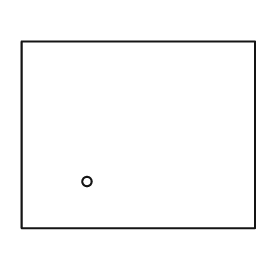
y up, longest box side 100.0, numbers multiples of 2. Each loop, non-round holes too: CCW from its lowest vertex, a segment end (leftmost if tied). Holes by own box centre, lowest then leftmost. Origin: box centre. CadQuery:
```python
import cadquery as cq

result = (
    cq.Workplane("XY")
    .moveTo(-50.0, -40.0)
    .lineTo(50.0, -40.0)
    .lineTo(50.0, 40.0)
    .lineTo(-50.0, 40.0)
    .close()
    .moveTo(-22.0, -20.0)
    .circle(2.0)
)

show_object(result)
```